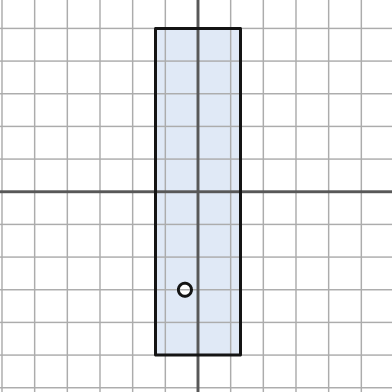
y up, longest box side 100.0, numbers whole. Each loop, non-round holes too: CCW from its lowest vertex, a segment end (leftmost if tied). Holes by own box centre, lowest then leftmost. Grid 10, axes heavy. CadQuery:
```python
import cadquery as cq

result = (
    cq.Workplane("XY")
    .moveTo(-13.0, -50.0)
    .lineTo(13.0, -50.0)
    .lineTo(13.0, 50.0)
    .lineTo(-13.0, 50.0)
    .close()
    .moveTo(-4.0, -30.0)
    .circle(2.0)
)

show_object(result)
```